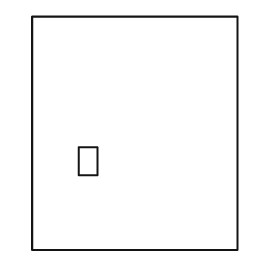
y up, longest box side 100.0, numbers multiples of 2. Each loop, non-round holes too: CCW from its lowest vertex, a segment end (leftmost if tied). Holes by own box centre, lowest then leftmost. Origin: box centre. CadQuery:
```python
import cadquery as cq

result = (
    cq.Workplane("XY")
    .moveTo(-44.0, -50.0)
    .lineTo(44.0, -50.0)
    .lineTo(44.0, 50.0)
    .lineTo(-44.0, 50.0)
    .close()
    .moveTo(-24.0, -18.0)
    .lineTo(-16.0, -18.0)
    .lineTo(-16.0, -6.0)
    .lineTo(-24.0, -6.0)
    .close()
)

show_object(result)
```